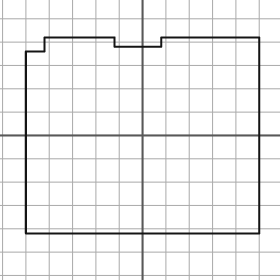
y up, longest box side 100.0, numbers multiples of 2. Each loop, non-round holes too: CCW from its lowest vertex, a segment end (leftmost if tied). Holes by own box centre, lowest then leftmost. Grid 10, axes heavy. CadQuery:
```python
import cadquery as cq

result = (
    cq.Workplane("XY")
    .moveTo(-50.0, -42.0)
    .lineTo(50.0, -42.0)
    .lineTo(50.0, 42.0)
    .lineTo(8.0, 42.0)
    .lineTo(8.0, 38.0)
    .lineTo(-12.0, 38.0)
    .lineTo(-12.0, 42.0)
    .lineTo(-42.0, 42.0)
    .lineTo(-42.0, 36.0)
    .lineTo(-50.0, 36.0)
    .close()
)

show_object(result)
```